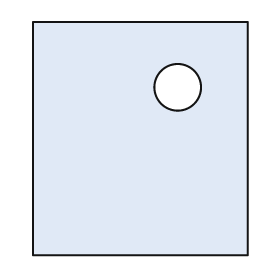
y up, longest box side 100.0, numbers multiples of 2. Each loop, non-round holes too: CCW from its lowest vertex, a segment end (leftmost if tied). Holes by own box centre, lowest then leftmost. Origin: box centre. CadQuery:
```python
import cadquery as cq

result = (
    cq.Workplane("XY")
    .moveTo(-46.0, -50.0)
    .lineTo(46.0, -50.0)
    .lineTo(46.0, 50.0)
    .lineTo(-46.0, 50.0)
    .close()
    .moveTo(16.0, 22.0)
    .circle(10.0)
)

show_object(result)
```